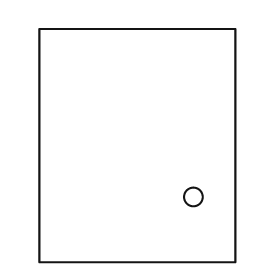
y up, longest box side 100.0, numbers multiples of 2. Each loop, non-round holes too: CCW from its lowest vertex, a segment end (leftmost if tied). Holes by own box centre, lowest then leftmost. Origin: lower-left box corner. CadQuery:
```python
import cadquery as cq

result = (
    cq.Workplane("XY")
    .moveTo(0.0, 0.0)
    .lineTo(84.0, 0.0)
    .lineTo(84.0, 100.0)
    .lineTo(0.0, 100.0)
    .close()
    .moveTo(66.0, 28.0)
    .circle(4.0)
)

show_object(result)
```